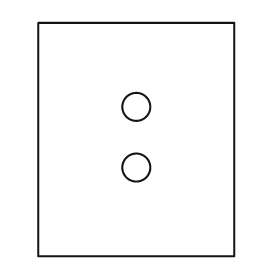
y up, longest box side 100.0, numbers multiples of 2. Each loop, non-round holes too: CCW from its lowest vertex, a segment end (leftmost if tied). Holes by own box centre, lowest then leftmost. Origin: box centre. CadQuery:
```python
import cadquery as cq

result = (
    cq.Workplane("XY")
    .moveTo(-42.0, -50.0)
    .lineTo(42.0, -50.0)
    .lineTo(42.0, 50.0)
    .lineTo(-42.0, 50.0)
    .close()
    .moveTo(0.0, -12.0)
    .circle(6.0)
    .moveTo(0.0, 14.0)
    .circle(6.0)
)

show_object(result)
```